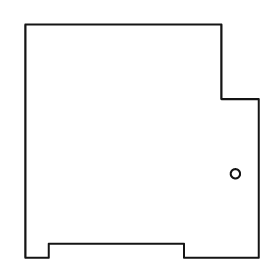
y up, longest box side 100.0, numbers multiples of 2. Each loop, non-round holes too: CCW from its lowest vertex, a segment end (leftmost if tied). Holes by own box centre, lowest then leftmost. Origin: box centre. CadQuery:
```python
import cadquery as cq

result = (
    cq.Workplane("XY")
    .moveTo(-50.0, -50.0)
    .lineTo(-40.0, -50.0)
    .lineTo(-40.0, -44.0)
    .lineTo(18.0, -44.0)
    .lineTo(18.0, -50.0)
    .lineTo(50.0, -50.0)
    .lineTo(50.0, 18.0)
    .lineTo(34.0, 18.0)
    .lineTo(34.0, 50.0)
    .lineTo(-50.0, 50.0)
    .close()
    .moveTo(40.0, -14.0)
    .circle(2.0)
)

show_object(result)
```